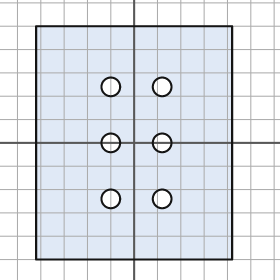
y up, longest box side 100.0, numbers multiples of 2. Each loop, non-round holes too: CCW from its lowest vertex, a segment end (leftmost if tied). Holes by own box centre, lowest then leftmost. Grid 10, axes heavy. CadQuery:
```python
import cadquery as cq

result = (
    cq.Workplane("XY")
    .moveTo(-42.0, -50.0)
    .lineTo(42.0, -50.0)
    .lineTo(42.0, 50.0)
    .lineTo(-42.0, 50.0)
    .close()
    .moveTo(-10.0, -24.0)
    .circle(4.0)
    .moveTo(12.0, -24.0)
    .circle(4.0)
    .moveTo(-10.0, 0.0)
    .circle(4.0)
    .moveTo(12.0, 0.0)
    .circle(4.0)
    .moveTo(-10.0, 24.0)
    .circle(4.0)
    .moveTo(12.0, 24.0)
    .circle(4.0)
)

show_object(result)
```